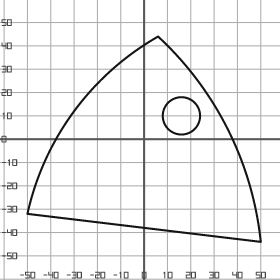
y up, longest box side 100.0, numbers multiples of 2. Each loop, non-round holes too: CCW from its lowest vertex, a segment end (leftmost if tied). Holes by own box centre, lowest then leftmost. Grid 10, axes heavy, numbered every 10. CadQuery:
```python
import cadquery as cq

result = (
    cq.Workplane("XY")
    .moveTo(50.0, -44.0)
    .threePointArc((36.0, 4.0), (6.0, 44.0))
    .threePointArc((-30.0, 12.0), (-50.0, -32.0))
    .close()
    .moveTo(16.0, 10.0)
    .circle(8.0)
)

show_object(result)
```